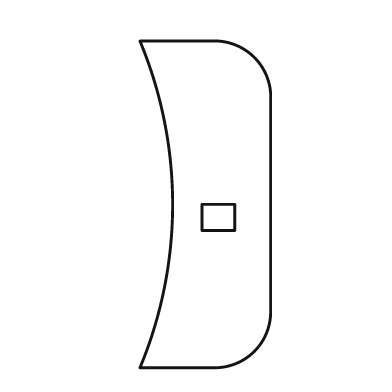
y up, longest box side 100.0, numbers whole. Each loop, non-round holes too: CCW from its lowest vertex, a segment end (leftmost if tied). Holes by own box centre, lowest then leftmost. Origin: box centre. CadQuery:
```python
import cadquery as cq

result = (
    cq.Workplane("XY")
    .moveTo(-20.0, -50.0)
    .lineTo(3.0, -50.0)
    .threePointArc((15.0, -45.0), (20.0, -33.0))
    .lineTo(20.0, 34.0)
    .threePointArc((15.0, 45.0), (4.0, 50.0))
    .lineTo(-20.0, 50.0)
    .threePointArc((-10.0, 0.0), (-20.0, -50.0))
    .close()
    .moveTo(-1.0, -8.0)
    .lineTo(9.0, -8.0)
    .lineTo(9.0, 0.0)
    .lineTo(-1.0, 0.0)
    .close()
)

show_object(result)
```